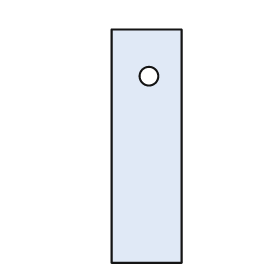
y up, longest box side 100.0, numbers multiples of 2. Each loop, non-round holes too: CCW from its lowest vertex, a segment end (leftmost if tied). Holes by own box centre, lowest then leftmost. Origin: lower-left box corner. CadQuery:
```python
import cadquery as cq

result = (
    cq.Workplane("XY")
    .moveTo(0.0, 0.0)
    .lineTo(30.0, 0.0)
    .lineTo(30.0, 100.0)
    .lineTo(0.0, 100.0)
    .close()
    .moveTo(16.0, 80.0)
    .circle(4.0)
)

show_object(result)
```